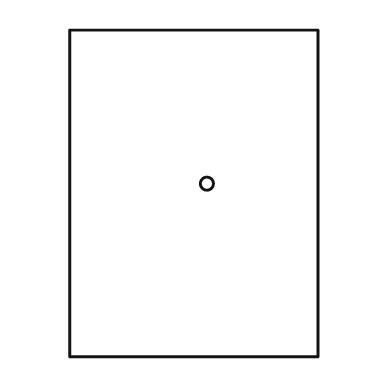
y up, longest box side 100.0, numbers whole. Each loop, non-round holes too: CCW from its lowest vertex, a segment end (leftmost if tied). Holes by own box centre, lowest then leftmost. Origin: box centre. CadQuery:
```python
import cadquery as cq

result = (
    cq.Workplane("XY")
    .moveTo(-38.0, -50.0)
    .lineTo(38.0, -50.0)
    .lineTo(38.0, 50.0)
    .lineTo(-38.0, 50.0)
    .close()
    .moveTo(4.0, 3.0)
    .circle(2.0)
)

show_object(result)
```